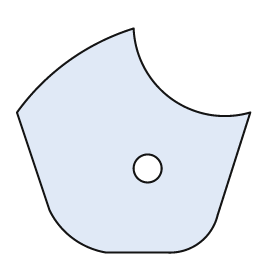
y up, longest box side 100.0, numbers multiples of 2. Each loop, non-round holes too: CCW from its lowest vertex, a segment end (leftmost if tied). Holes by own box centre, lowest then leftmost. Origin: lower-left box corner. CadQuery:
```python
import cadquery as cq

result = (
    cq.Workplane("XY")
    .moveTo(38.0, 0.0)
    .lineTo(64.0, 0.0)
    .threePointArc((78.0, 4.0), (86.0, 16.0))
    .lineTo(100.0, 60.0)
    .threePointArc((66.0, 66.0), (50.0, 96.0))
    .threePointArc((22.0, 82.0), (0.0, 60.0))
    .lineTo(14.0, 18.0)
    .threePointArc((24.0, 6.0), (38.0, 0.0))
    .close()
    .moveTo(56.0, 36.0)
    .circle(6.0)
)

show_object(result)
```